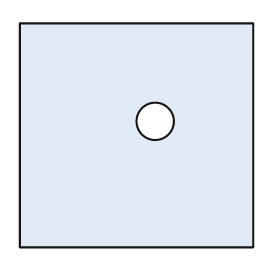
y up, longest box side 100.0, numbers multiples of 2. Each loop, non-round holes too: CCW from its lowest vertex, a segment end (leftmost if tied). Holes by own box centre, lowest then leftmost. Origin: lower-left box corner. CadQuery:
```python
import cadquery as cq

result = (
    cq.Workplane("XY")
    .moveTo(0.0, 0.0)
    .lineTo(100.0, 0.0)
    .lineTo(100.0, 96.0)
    .lineTo(0.0, 96.0)
    .close()
    .moveTo(58.0, 54.0)
    .circle(8.0)
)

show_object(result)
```